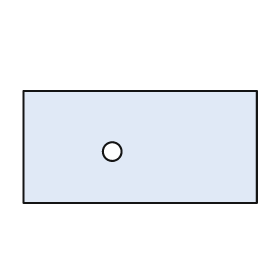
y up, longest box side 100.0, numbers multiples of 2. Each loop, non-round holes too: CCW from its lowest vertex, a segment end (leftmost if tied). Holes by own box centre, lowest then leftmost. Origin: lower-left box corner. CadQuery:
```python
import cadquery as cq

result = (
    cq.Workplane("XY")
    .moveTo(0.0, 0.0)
    .lineTo(100.0, 0.0)
    .lineTo(100.0, 48.0)
    .lineTo(0.0, 48.0)
    .close()
    .moveTo(38.0, 22.0)
    .circle(4.0)
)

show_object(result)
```